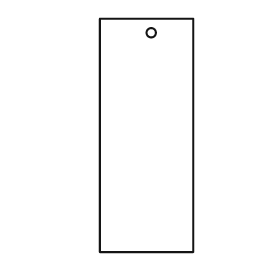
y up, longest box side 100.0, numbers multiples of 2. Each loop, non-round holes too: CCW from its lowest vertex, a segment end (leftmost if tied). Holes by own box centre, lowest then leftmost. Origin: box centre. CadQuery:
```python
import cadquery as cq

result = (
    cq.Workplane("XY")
    .moveTo(-20.0, -50.0)
    .lineTo(20.0, -50.0)
    .lineTo(20.0, 50.0)
    .lineTo(-20.0, 50.0)
    .close()
    .moveTo(2.0, 44.0)
    .circle(2.0)
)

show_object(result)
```